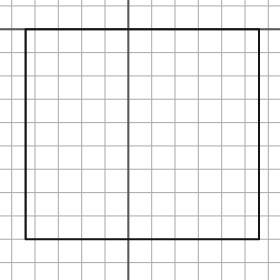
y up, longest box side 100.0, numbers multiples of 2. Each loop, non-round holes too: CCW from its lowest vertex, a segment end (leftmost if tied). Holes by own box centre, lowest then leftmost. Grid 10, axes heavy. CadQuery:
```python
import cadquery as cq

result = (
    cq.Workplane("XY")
    .moveTo(-44.0, -90.0)
    .lineTo(56.0, -90.0)
    .lineTo(56.0, 0.0)
    .lineTo(-44.0, 0.0)
    .close()
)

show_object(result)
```